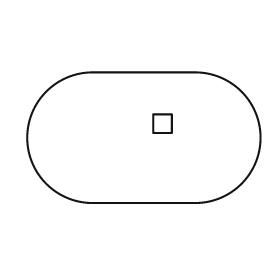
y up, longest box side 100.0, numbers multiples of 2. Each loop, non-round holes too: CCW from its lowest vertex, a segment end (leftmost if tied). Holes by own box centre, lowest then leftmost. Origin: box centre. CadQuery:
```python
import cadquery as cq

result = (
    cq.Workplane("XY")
    .moveTo(-22.0, -28.0)
    .lineTo(22.0, -28.0)
    .threePointArc((50.0, 0.0), (22.0, 28.0))
    .lineTo(-22.0, 28.0)
    .threePointArc((-50.0, 0.0), (-22.0, -28.0))
    .close()
    .moveTo(4.0, 2.0)
    .lineTo(12.0, 2.0)
    .lineTo(12.0, 10.0)
    .lineTo(4.0, 10.0)
    .close()
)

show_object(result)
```